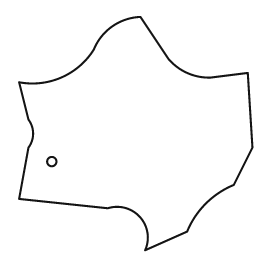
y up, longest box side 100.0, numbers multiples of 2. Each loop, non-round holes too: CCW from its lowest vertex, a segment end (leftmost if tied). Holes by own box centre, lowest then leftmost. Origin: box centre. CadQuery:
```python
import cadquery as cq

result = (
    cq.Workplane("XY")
    .moveTo(4.0, -50.0)
    .lineTo(22.0, -42.0)
    .threePointArc((30.0, -30.0), (42.0, -22.0))
    .lineTo(50.0, -6.0)
    .lineTo(48.0, 26.0)
    .lineTo(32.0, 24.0)
    .threePointArc((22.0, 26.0), (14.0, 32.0))
    .lineTo(2.0, 50.0)
    .threePointArc((-10.0, 46.0), (-18.0, 36.0))
    .threePointArc((-32.0, 24.0), (-50.0, 22.0))
    .lineTo(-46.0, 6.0)
    .threePointArc((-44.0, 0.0), (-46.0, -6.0))
    .lineTo(-50.0, -28.0)
    .lineTo(-12.0, -32.0)
    .threePointArc((2.0, -36.0), (4.0, -50.0))
    .close()
    .moveTo(-36.0, -12.0)
    .circle(2.0)
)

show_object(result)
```